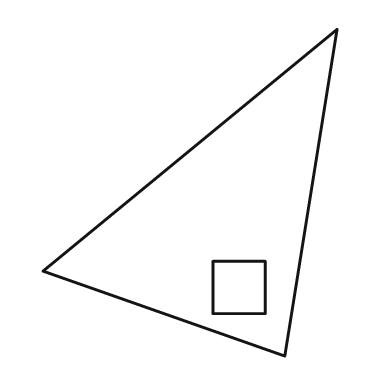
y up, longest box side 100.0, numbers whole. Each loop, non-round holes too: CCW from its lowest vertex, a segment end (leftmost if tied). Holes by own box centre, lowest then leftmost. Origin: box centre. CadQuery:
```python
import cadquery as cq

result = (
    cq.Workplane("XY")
    .moveTo(29.0, -50.0)
    .lineTo(45.0, 50.0)
    .lineTo(-45.0, -24.0)
    .close()
    .moveTo(7.0, -37.0)
    .lineTo(23.0, -37.0)
    .lineTo(23.0, -21.0)
    .lineTo(7.0, -21.0)
    .close()
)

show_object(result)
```